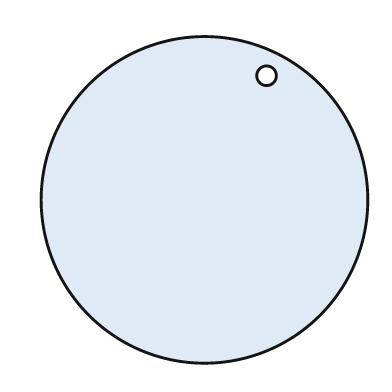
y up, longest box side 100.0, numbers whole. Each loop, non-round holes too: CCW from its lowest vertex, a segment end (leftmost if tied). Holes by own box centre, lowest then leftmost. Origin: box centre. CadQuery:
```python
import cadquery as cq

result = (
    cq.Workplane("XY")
    .moveTo(0.0, 0.0)
    .circle(50.0)
    .moveTo(19.0, 38.0)
    .circle(3.0)
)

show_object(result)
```